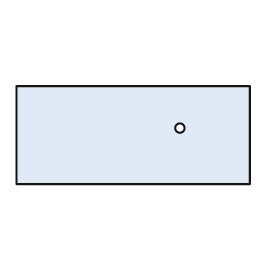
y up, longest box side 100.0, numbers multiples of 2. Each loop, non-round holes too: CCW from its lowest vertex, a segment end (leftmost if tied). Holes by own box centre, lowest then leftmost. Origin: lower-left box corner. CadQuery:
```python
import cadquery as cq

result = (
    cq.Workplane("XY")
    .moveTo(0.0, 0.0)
    .lineTo(100.0, 0.0)
    .lineTo(100.0, 42.0)
    .lineTo(0.0, 42.0)
    .close()
    .moveTo(70.0, 24.0)
    .circle(2.0)
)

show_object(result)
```